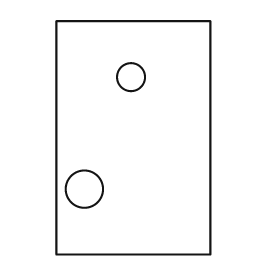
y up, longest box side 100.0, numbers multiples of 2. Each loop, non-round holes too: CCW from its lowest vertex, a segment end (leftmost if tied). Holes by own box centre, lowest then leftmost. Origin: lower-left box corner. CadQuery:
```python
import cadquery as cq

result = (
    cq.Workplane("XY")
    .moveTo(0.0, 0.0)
    .lineTo(66.0, 0.0)
    .lineTo(66.0, 100.0)
    .lineTo(0.0, 100.0)
    .close()
    .moveTo(12.0, 28.0)
    .circle(8.0)
    .moveTo(32.0, 76.0)
    .circle(6.0)
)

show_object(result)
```